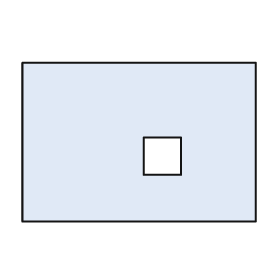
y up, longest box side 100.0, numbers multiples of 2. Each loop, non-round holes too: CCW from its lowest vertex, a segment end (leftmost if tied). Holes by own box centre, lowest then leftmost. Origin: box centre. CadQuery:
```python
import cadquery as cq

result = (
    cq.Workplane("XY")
    .moveTo(-50.0, -34.0)
    .lineTo(50.0, -34.0)
    .lineTo(50.0, 34.0)
    .lineTo(-50.0, 34.0)
    .close()
    .moveTo(2.0, -14.0)
    .lineTo(18.0, -14.0)
    .lineTo(18.0, 2.0)
    .lineTo(2.0, 2.0)
    .close()
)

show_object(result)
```